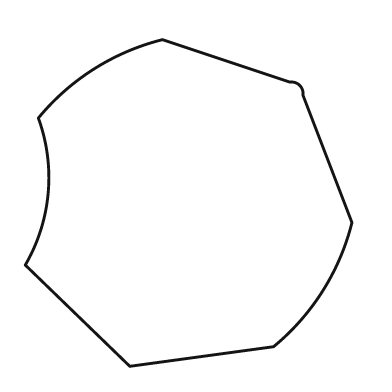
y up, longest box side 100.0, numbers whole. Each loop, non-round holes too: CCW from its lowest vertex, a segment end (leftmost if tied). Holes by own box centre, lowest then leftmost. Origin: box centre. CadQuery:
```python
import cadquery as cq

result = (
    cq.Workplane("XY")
    .moveTo(-18.0, -50.0)
    .lineTo(26.0, -44.0)
    .threePointArc((41.0, -27.0), (50.0, -6.0))
    .lineTo(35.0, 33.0)
    .threePointArc((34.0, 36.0), (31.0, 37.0))
    .lineTo(-8.0, 50.0)
    .threePointArc((-29.0, 41.0), (-46.0, 26.0))
    .threePointArc((-43.0, 3.0), (-50.0, -19.0))
    .close()
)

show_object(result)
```